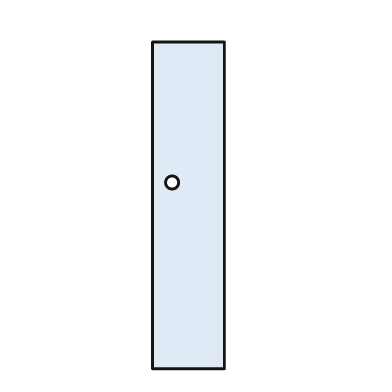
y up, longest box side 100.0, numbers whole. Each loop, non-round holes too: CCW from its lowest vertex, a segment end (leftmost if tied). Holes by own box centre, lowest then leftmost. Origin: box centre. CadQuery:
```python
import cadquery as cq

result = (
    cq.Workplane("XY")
    .moveTo(-11.0, -50.0)
    .lineTo(11.0, -50.0)
    .lineTo(11.0, 50.0)
    .lineTo(-11.0, 50.0)
    .close()
    .moveTo(-5.0, 7.0)
    .circle(2.0)
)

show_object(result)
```